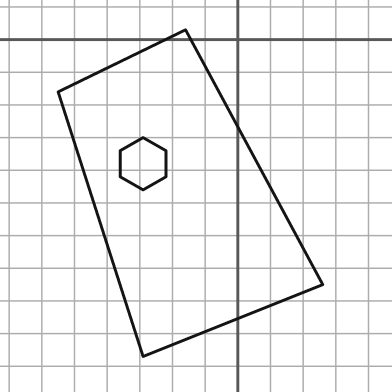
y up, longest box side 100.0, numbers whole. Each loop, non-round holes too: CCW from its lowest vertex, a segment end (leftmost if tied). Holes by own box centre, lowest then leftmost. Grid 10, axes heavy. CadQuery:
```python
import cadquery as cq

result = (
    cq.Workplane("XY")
    .moveTo(-29.0, -97.0)
    .lineTo(26.0, -75.0)
    .lineTo(-16.0, 3.0)
    .lineTo(-55.0, -16.0)
    .close()
    .moveTo(-29.0, -46.0)
    .lineTo(-22.0, -42.0)
    .lineTo(-22.0, -34.0)
    .lineTo(-29.0, -30.0)
    .lineTo(-36.0, -34.0)
    .lineTo(-36.0, -42.0)
    .close()
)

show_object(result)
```